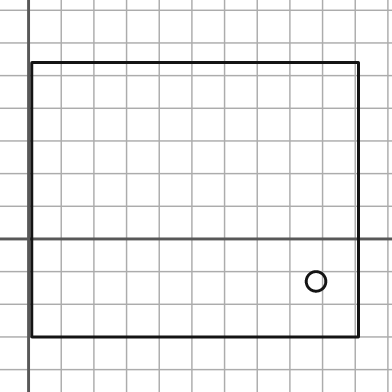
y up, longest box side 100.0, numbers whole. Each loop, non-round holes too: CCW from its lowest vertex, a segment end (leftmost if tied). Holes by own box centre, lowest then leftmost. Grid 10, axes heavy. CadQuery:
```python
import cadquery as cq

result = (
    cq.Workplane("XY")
    .moveTo(1.0, -30.0)
    .lineTo(101.0, -30.0)
    .lineTo(101.0, 54.0)
    .lineTo(1.0, 54.0)
    .close()
    .moveTo(88.0, -13.0)
    .circle(3.0)
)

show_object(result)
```